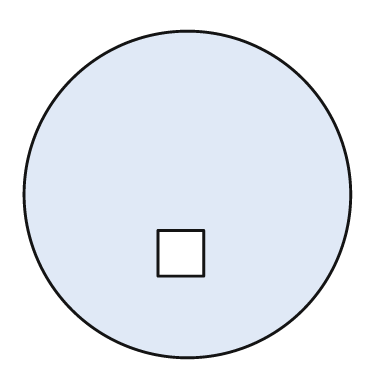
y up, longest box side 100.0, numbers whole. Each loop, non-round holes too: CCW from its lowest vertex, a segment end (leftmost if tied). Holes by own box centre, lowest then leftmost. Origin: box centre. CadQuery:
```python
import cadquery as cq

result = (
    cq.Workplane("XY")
    .moveTo(0.0, 0.0)
    .circle(50.0)
    .moveTo(-9.0, -25.0)
    .lineTo(5.0, -25.0)
    .lineTo(5.0, -11.0)
    .lineTo(-9.0, -11.0)
    .close()
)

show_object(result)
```